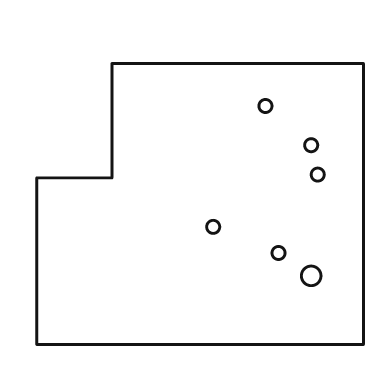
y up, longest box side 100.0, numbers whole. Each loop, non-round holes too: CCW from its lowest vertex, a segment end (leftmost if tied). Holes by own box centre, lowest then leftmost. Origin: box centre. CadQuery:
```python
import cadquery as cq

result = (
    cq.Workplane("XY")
    .moveTo(-50.0, -43.0)
    .lineTo(50.0, -43.0)
    .lineTo(50.0, 43.0)
    .lineTo(-27.0, 43.0)
    .lineTo(-27.0, 8.0)
    .lineTo(-50.0, 8.0)
    .close()
    .moveTo(34.0, -22.0)
    .circle(3.0)
    .moveTo(24.0, -15.0)
    .circle(2.0)
    .moveTo(4.0, -7.0)
    .circle(2.0)
    .moveTo(36.0, 9.0)
    .circle(2.0)
    .moveTo(34.0, 18.0)
    .circle(2.0)
    .moveTo(20.0, 30.0)
    .circle(2.0)
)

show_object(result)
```